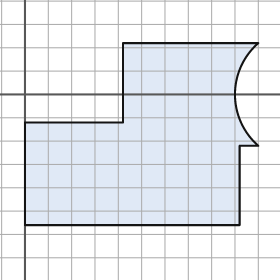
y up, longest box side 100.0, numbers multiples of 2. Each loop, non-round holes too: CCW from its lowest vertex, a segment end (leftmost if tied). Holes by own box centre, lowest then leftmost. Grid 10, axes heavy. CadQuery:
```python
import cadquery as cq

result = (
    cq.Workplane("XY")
    .moveTo(0.0, -56.0)
    .lineTo(92.0, -56.0)
    .lineTo(92.0, -22.0)
    .lineTo(100.0, -22.0)
    .threePointArc((90.0, 0.0), (100.0, 22.0))
    .lineTo(42.0, 22.0)
    .lineTo(42.0, -12.0)
    .lineTo(0.0, -12.0)
    .close()
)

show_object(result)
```